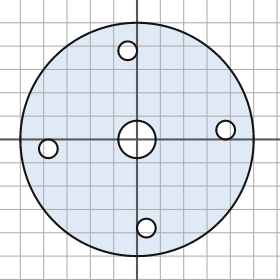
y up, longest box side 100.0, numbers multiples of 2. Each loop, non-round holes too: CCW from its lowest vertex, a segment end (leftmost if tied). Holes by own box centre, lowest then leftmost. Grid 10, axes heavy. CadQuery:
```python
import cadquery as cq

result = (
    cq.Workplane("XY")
    .moveTo(0.0, 0.0)
    .circle(50.0)
    .moveTo(4.0, -38.0)
    .circle(4.0)
    .moveTo(-38.0, -4.0)
    .circle(4.0)
    .moveTo(0.0, 0.0)
    .circle(8.0)
    .moveTo(38.0, 4.0)
    .circle(4.0)
    .moveTo(-4.0, 38.0)
    .circle(4.0)
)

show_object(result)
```